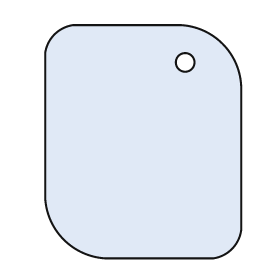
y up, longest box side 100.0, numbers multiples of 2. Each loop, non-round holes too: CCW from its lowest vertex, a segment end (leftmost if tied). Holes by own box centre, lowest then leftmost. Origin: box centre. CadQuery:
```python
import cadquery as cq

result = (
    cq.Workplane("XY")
    .moveTo(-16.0, -50.0)
    .lineTo(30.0, -50.0)
    .threePointArc((38.0, -46.0), (42.0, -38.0))
    .lineTo(42.0, 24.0)
    .threePointArc((34.0, 42.0), (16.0, 50.0))
    .lineTo(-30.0, 50.0)
    .threePointArc((-38.0, 46.0), (-42.0, 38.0))
    .lineTo(-42.0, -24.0)
    .threePointArc((-34.0, -42.0), (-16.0, -50.0))
    .close()
    .moveTo(18.0, 34.0)
    .circle(4.0)
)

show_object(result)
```